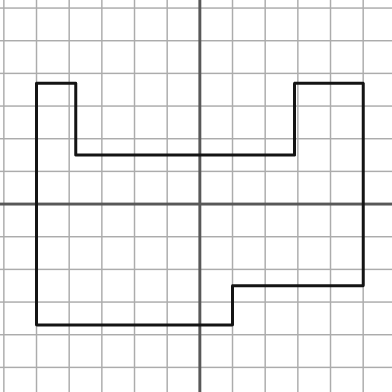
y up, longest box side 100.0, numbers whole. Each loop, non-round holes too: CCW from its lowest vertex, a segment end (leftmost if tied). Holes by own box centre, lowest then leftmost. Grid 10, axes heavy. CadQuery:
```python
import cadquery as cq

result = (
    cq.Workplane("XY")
    .moveTo(-50.0, -37.0)
    .lineTo(10.0, -37.0)
    .lineTo(10.0, -25.0)
    .lineTo(50.0, -25.0)
    .lineTo(50.0, 37.0)
    .lineTo(29.0, 37.0)
    .lineTo(29.0, 15.0)
    .lineTo(-38.0, 15.0)
    .lineTo(-38.0, 37.0)
    .lineTo(-50.0, 37.0)
    .close()
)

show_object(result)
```